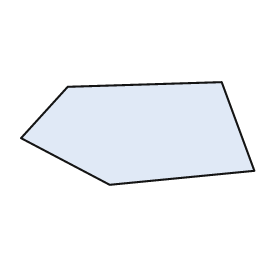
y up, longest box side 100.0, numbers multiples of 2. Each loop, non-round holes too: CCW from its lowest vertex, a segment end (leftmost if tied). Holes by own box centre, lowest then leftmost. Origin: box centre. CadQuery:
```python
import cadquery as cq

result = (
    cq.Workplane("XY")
    .moveTo(-12.0, -22.0)
    .lineTo(50.0, -16.0)
    .lineTo(36.0, 22.0)
    .lineTo(-30.0, 20.0)
    .lineTo(-50.0, -2.0)
    .close()
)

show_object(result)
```